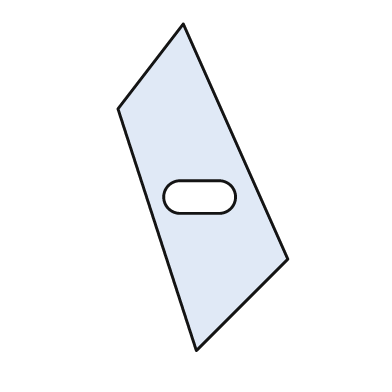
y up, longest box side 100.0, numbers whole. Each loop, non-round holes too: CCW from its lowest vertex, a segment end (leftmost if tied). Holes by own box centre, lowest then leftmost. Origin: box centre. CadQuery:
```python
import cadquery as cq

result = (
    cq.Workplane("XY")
    .moveTo(-2.0, -50.0)
    .lineTo(26.0, -22.0)
    .lineTo(-6.0, 50.0)
    .lineTo(-26.0, 24.0)
    .close()
    .moveTo(-7.0, -8.0)
    .lineTo(5.0, -8.0)
    .threePointArc((10.0, -3.0), (5.0, 2.0))
    .lineTo(-7.0, 2.0)
    .threePointArc((-12.0, -3.0), (-7.0, -8.0))
    .close()
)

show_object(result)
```